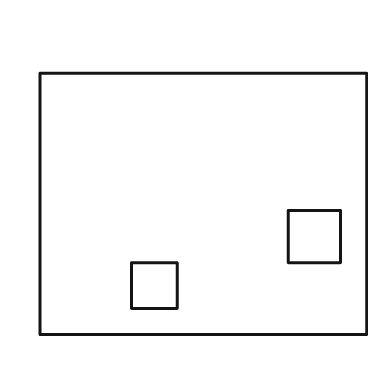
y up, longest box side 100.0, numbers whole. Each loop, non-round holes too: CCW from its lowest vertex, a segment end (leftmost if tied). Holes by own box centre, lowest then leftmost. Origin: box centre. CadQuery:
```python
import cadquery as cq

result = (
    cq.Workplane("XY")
    .moveTo(-50.0, -40.0)
    .lineTo(50.0, -40.0)
    .lineTo(50.0, 40.0)
    .lineTo(-50.0, 40.0)
    .close()
    .moveTo(-22.0, -32.0)
    .lineTo(-8.0, -32.0)
    .lineTo(-8.0, -18.0)
    .lineTo(-22.0, -18.0)
    .close()
    .moveTo(26.0, -18.0)
    .lineTo(42.0, -18.0)
    .lineTo(42.0, -2.0)
    .lineTo(26.0, -2.0)
    .close()
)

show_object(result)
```